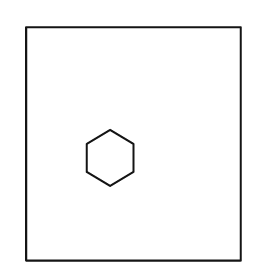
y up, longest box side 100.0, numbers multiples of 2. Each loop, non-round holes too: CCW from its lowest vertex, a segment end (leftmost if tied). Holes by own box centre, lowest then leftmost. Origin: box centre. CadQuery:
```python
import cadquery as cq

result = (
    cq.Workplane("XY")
    .moveTo(-46.0, -50.0)
    .lineTo(46.0, -50.0)
    .lineTo(46.0, 50.0)
    .lineTo(-46.0, 50.0)
    .close()
    .moveTo(-10.0, -18.0)
    .lineTo(0.0, -12.0)
    .lineTo(0.0, 0.0)
    .lineTo(-10.0, 6.0)
    .lineTo(-20.0, 0.0)
    .lineTo(-20.0, -12.0)
    .close()
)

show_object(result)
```